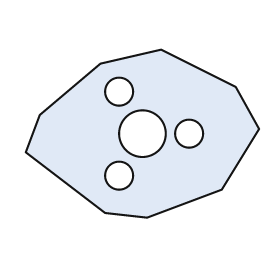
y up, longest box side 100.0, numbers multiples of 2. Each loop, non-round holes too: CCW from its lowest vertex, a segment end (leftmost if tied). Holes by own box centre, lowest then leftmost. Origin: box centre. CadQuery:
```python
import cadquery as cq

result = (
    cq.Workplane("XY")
    .moveTo(2.0, -36.0)
    .lineTo(34.0, -24.0)
    .lineTo(50.0, 2.0)
    .lineTo(40.0, 20.0)
    .lineTo(8.0, 36.0)
    .lineTo(-18.0, 30.0)
    .lineTo(-44.0, 8.0)
    .lineTo(-50.0, -8.0)
    .lineTo(-16.0, -34.0)
    .close()
    .moveTo(-10.0, -18.0)
    .circle(6.0)
    .moveTo(0.0, 0.0)
    .circle(10.0)
    .moveTo(20.0, 0.0)
    .circle(6.0)
    .moveTo(-10.0, 18.0)
    .circle(6.0)
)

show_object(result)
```